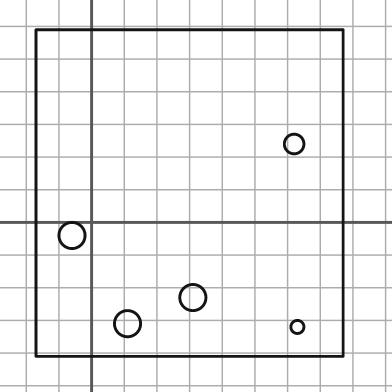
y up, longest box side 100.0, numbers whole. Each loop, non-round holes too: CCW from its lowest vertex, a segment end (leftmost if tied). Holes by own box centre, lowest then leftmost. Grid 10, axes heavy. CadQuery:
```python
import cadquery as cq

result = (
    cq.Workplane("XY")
    .moveTo(-17.0, -41.0)
    .lineTo(77.0, -41.0)
    .lineTo(77.0, 59.0)
    .lineTo(-17.0, 59.0)
    .close()
    .moveTo(63.0, -32.0)
    .circle(2.0)
    .moveTo(11.0, -31.0)
    .circle(4.0)
    .moveTo(31.0, -23.0)
    .circle(4.0)
    .moveTo(-6.0, -4.0)
    .circle(4.0)
    .moveTo(62.0, 24.0)
    .circle(3.0)
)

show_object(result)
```